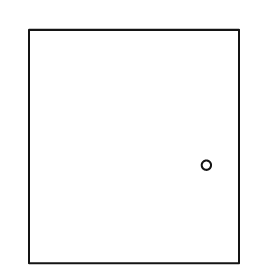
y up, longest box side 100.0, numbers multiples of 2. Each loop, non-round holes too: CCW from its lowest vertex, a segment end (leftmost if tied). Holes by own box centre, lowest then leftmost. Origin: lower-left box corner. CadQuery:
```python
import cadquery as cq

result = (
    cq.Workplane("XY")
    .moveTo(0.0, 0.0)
    .lineTo(90.0, 0.0)
    .lineTo(90.0, 100.0)
    .lineTo(0.0, 100.0)
    .close()
    .moveTo(76.0, 42.0)
    .circle(2.0)
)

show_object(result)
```